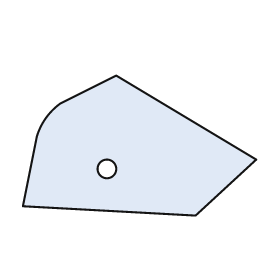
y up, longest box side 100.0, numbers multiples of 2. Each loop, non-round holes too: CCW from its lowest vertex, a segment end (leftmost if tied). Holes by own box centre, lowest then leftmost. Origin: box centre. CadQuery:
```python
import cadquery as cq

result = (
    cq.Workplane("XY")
    .moveTo(24.0, -30.0)
    .lineTo(50.0, -6.0)
    .lineTo(-10.0, 30.0)
    .lineTo(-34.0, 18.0)
    .threePointArc((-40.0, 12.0), (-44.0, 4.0))
    .lineTo(-50.0, -26.0)
    .close()
    .moveTo(-14.0, -10.0)
    .circle(4.0)
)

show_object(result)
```